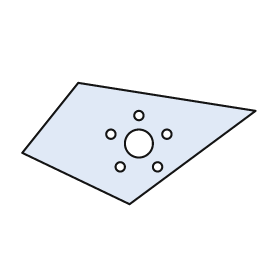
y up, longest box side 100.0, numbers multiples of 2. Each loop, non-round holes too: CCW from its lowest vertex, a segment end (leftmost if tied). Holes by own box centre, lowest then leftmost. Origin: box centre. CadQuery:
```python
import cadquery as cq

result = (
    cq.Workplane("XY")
    .moveTo(-4.0, -26.0)
    .lineTo(50.0, 14.0)
    .lineTo(-26.0, 26.0)
    .lineTo(-50.0, -4.0)
    .close()
    .moveTo(-8.0, -10.0)
    .circle(2.0)
    .moveTo(8.0, -10.0)
    .circle(2.0)
    .moveTo(0.0, 0.0)
    .circle(6.0)
    .moveTo(-12.0, 4.0)
    .circle(2.0)
    .moveTo(12.0, 4.0)
    .circle(2.0)
    .moveTo(0.0, 12.0)
    .circle(2.0)
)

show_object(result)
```